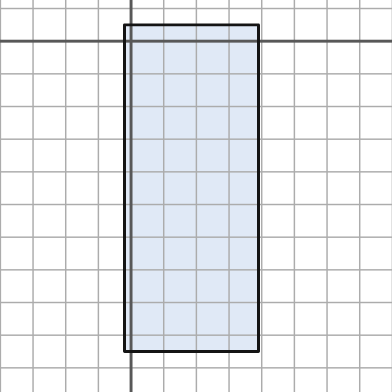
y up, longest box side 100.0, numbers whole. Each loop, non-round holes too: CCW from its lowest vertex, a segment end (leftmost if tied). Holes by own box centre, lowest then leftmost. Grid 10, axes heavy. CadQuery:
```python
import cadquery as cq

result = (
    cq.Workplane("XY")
    .moveTo(-2.0, -95.0)
    .lineTo(39.0, -95.0)
    .lineTo(39.0, 5.0)
    .lineTo(-2.0, 5.0)
    .close()
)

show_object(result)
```